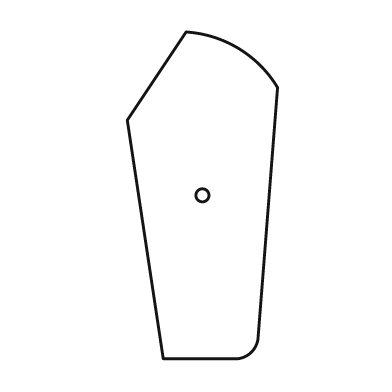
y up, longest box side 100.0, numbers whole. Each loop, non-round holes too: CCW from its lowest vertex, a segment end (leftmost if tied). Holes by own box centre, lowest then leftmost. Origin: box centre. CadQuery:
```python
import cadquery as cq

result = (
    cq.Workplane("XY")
    .moveTo(-12.0, -50.0)
    .lineTo(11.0, -50.0)
    .threePointArc((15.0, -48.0), (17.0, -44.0))
    .lineTo(23.0, 33.0)
    .threePointArc((11.0, 45.0), (-5.0, 50.0))
    .lineTo(-23.0, 23.0)
    .close()
    .moveTo(0.0, 0.0)
    .circle(2.0)
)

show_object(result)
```